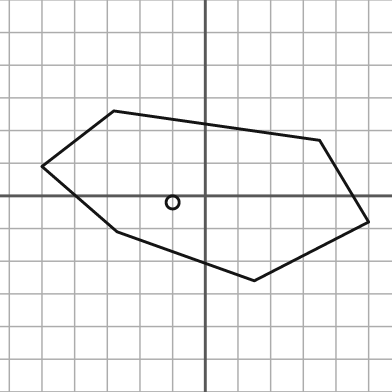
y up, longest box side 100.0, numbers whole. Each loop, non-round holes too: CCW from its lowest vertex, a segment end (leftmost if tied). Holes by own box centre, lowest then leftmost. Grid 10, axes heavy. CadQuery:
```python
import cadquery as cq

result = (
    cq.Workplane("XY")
    .moveTo(15.0, -26.0)
    .lineTo(50.0, -8.0)
    .lineTo(35.0, 17.0)
    .lineTo(-28.0, 26.0)
    .lineTo(-50.0, 9.0)
    .lineTo(-27.0, -11.0)
    .close()
    .moveTo(-10.0, -2.0)
    .circle(2.0)
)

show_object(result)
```